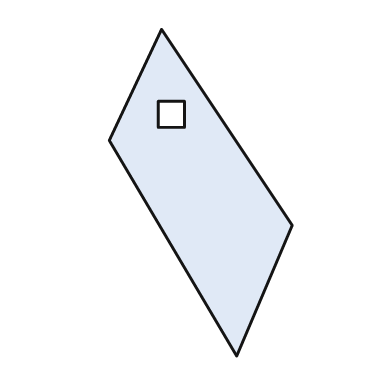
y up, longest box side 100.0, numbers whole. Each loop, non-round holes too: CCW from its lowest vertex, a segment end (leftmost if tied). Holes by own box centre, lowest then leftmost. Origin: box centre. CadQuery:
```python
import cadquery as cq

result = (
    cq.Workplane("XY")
    .moveTo(11.0, -50.0)
    .lineTo(28.0, -10.0)
    .lineTo(-12.0, 50.0)
    .lineTo(-28.0, 16.0)
    .close()
    .moveTo(-13.0, 20.0)
    .lineTo(-5.0, 20.0)
    .lineTo(-5.0, 28.0)
    .lineTo(-13.0, 28.0)
    .close()
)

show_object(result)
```